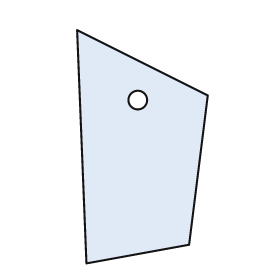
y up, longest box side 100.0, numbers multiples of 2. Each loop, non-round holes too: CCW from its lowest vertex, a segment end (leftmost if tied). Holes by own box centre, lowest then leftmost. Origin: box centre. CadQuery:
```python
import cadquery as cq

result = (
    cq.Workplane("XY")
    .moveTo(-24.0, -50.0)
    .lineTo(20.0, -42.0)
    .lineTo(28.0, 22.0)
    .lineTo(-28.0, 50.0)
    .close()
    .moveTo(-2.0, 20.0)
    .circle(4.0)
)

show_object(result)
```